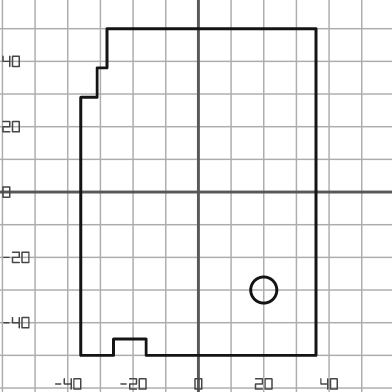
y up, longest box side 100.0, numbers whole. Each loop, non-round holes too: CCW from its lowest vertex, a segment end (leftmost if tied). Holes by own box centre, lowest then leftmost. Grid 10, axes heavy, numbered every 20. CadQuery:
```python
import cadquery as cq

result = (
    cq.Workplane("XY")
    .moveTo(-36.0, -50.0)
    .lineTo(-26.0, -50.0)
    .lineTo(-26.0, -45.0)
    .lineTo(-16.0, -45.0)
    .lineTo(-16.0, -50.0)
    .lineTo(36.0, -50.0)
    .lineTo(36.0, 50.0)
    .lineTo(-28.0, 50.0)
    .lineTo(-28.0, 38.0)
    .lineTo(-31.0, 38.0)
    .lineTo(-31.0, 29.0)
    .lineTo(-36.0, 29.0)
    .close()
    .moveTo(20.0, -30.0)
    .circle(4.0)
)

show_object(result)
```